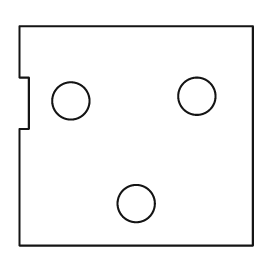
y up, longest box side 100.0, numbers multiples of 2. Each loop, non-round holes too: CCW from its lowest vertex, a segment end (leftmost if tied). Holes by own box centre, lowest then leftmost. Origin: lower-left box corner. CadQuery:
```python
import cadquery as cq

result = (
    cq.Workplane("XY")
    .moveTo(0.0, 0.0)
    .lineTo(100.0, 0.0)
    .lineTo(100.0, 94.0)
    .lineTo(0.0, 94.0)
    .lineTo(0.0, 72.0)
    .lineTo(4.0, 72.0)
    .lineTo(4.0, 50.0)
    .lineTo(0.0, 50.0)
    .close()
    .moveTo(50.0, 18.0)
    .circle(8.0)
    .moveTo(22.0, 62.0)
    .circle(8.0)
    .moveTo(76.0, 64.0)
    .circle(8.0)
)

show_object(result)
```